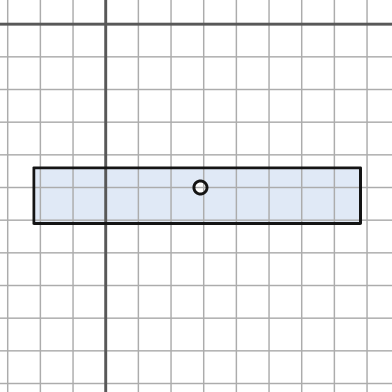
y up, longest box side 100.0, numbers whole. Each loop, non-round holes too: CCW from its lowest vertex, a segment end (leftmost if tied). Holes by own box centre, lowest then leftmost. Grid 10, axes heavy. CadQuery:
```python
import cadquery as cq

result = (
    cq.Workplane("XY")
    .moveTo(-22.0, -61.0)
    .lineTo(78.0, -61.0)
    .lineTo(78.0, -44.0)
    .lineTo(-22.0, -44.0)
    .close()
    .moveTo(29.0, -50.0)
    .circle(2.0)
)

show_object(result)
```